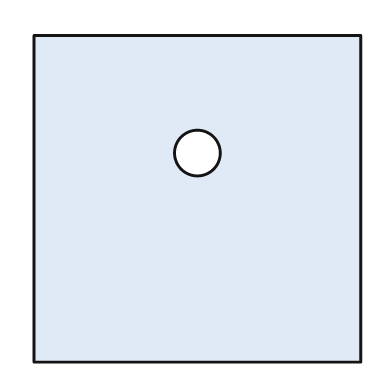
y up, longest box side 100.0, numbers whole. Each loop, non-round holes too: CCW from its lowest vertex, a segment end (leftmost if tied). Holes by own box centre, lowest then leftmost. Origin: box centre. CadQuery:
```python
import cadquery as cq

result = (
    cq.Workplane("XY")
    .moveTo(-50.0, -50.0)
    .lineTo(50.0, -50.0)
    .lineTo(50.0, 50.0)
    .lineTo(-50.0, 50.0)
    .close()
    .moveTo(0.0, 14.0)
    .circle(7.0)
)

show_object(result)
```